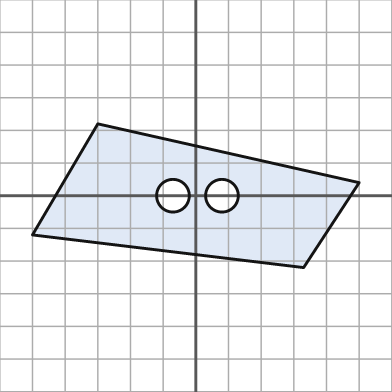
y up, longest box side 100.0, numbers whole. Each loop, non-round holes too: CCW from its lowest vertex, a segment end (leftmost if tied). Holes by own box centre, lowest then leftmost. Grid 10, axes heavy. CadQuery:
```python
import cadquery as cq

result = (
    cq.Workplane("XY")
    .moveTo(33.0, -22.0)
    .lineTo(50.0, 4.0)
    .lineTo(-30.0, 22.0)
    .lineTo(-50.0, -12.0)
    .close()
    .moveTo(-7.0, 0.0)
    .circle(5.0)
    .moveTo(8.0, 0.0)
    .circle(5.0)
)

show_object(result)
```